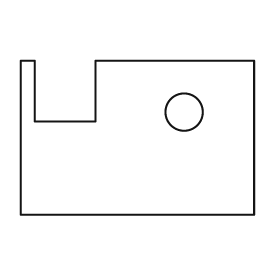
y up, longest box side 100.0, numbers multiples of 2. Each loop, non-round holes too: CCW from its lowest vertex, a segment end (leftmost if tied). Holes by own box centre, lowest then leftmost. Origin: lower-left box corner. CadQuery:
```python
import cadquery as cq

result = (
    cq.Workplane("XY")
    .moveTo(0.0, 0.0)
    .lineTo(100.0, 0.0)
    .lineTo(100.0, 66.0)
    .lineTo(32.0, 66.0)
    .lineTo(32.0, 40.0)
    .lineTo(6.0, 40.0)
    .lineTo(6.0, 66.0)
    .lineTo(0.0, 66.0)
    .close()
    .moveTo(70.0, 44.0)
    .circle(8.0)
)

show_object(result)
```